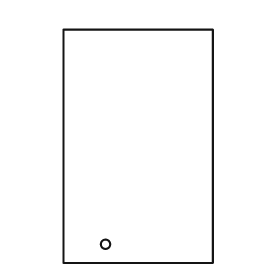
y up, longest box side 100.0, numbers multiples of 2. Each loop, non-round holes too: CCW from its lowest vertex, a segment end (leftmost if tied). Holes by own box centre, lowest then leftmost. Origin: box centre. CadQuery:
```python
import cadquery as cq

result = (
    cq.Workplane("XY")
    .moveTo(-32.0, -50.0)
    .lineTo(32.0, -50.0)
    .lineTo(32.0, 50.0)
    .lineTo(-32.0, 50.0)
    .close()
    .moveTo(-14.0, -42.0)
    .circle(2.0)
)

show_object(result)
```